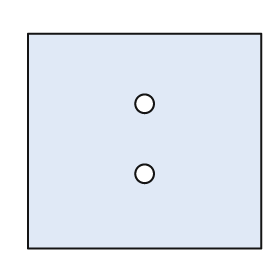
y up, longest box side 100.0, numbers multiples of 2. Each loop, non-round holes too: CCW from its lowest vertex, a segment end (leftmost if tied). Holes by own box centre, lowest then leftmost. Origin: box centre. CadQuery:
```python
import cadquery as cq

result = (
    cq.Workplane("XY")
    .moveTo(-50.0, -46.0)
    .lineTo(50.0, -46.0)
    .lineTo(50.0, 46.0)
    .lineTo(-50.0, 46.0)
    .close()
    .moveTo(0.0, -14.0)
    .circle(4.0)
    .moveTo(0.0, 16.0)
    .circle(4.0)
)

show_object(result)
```